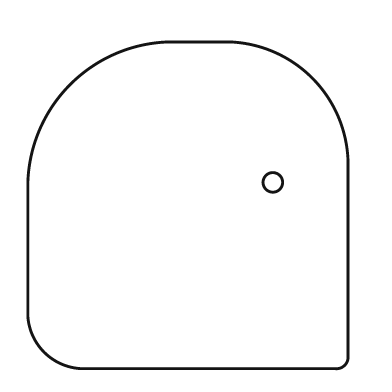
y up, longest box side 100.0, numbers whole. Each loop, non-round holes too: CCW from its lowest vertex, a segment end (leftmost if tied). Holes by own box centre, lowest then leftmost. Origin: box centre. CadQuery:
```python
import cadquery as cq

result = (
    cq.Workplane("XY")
    .moveTo(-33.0, -50.0)
    .lineTo(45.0, -50.0)
    .threePointArc((48.0, -49.0), (49.0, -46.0))
    .lineTo(49.0, 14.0)
    .threePointArc((38.0, 39.0), (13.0, 50.0))
    .lineTo(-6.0, 50.0)
    .threePointArc((-36.0, 37.0), (-49.0, 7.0))
    .lineTo(-49.0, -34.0)
    .threePointArc((-44.0, -45.0), (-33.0, -50.0))
    .close()
    .moveTo(26.0, 7.0)
    .circle(3.0)
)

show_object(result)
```